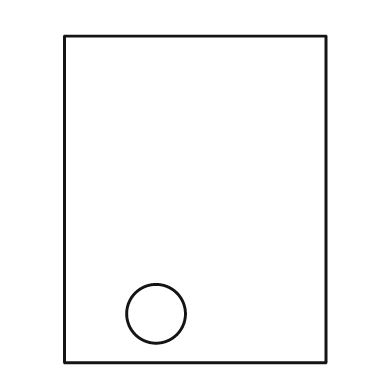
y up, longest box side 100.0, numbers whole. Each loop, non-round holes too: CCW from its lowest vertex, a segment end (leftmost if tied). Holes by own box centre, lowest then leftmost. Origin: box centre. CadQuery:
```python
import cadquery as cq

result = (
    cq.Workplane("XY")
    .moveTo(-40.0, -50.0)
    .lineTo(40.0, -50.0)
    .lineTo(40.0, 50.0)
    .lineTo(-40.0, 50.0)
    .close()
    .moveTo(-12.0, -35.0)
    .circle(9.0)
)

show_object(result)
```